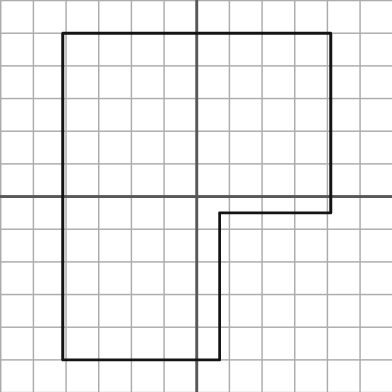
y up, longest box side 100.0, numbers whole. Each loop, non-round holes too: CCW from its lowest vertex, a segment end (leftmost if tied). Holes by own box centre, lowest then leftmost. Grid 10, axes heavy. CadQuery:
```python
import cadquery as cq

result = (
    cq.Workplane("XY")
    .moveTo(-41.0, -50.0)
    .lineTo(7.0, -50.0)
    .lineTo(7.0, -5.0)
    .lineTo(41.0, -5.0)
    .lineTo(41.0, 50.0)
    .lineTo(-41.0, 50.0)
    .close()
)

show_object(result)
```